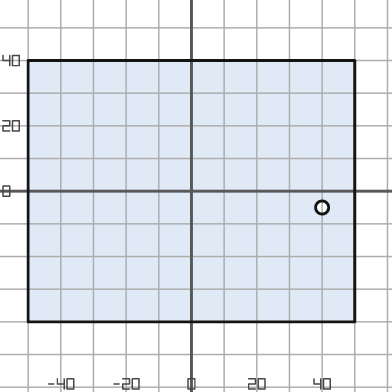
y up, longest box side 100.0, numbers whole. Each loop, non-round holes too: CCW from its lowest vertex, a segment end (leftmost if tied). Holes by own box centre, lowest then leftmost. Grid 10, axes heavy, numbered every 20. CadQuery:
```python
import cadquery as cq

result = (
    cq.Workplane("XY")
    .moveTo(-50.0, -40.0)
    .lineTo(50.0, -40.0)
    .lineTo(50.0, 40.0)
    .lineTo(-50.0, 40.0)
    .close()
    .moveTo(40.0, -5.0)
    .circle(2.0)
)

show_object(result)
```